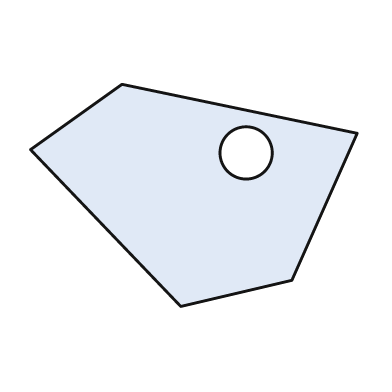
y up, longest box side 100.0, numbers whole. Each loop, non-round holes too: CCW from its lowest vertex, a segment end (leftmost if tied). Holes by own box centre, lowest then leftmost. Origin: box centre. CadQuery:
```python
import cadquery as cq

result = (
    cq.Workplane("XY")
    .moveTo(-4.0, -34.0)
    .lineTo(30.0, -26.0)
    .lineTo(50.0, 19.0)
    .lineTo(-22.0, 34.0)
    .lineTo(-50.0, 14.0)
    .close()
    .moveTo(16.0, 13.0)
    .circle(8.0)
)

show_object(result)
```